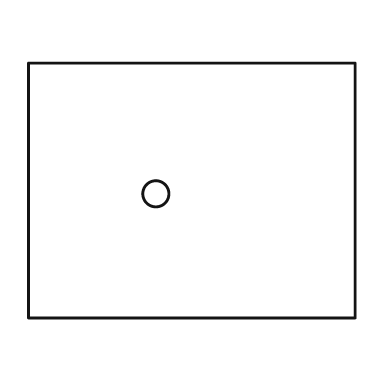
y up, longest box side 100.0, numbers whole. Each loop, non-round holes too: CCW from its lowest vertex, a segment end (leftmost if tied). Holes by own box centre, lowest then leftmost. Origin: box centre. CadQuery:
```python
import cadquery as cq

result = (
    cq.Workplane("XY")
    .moveTo(-50.0, -39.0)
    .lineTo(50.0, -39.0)
    .lineTo(50.0, 39.0)
    .lineTo(-50.0, 39.0)
    .close()
    .moveTo(-11.0, -1.0)
    .circle(4.0)
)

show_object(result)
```